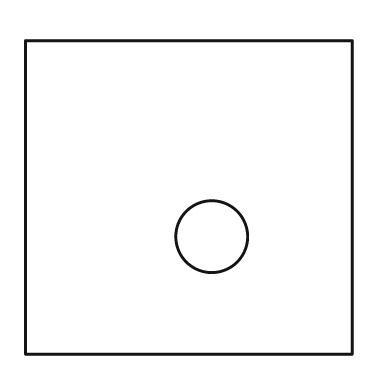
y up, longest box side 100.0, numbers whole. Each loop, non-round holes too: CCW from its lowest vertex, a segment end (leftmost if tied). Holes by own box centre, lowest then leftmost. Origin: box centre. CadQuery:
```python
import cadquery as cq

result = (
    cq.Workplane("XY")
    .moveTo(-50.0, -48.0)
    .lineTo(50.0, -48.0)
    .lineTo(50.0, 48.0)
    .lineTo(-50.0, 48.0)
    .close()
    .moveTo(7.0, -12.0)
    .circle(11.0)
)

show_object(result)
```